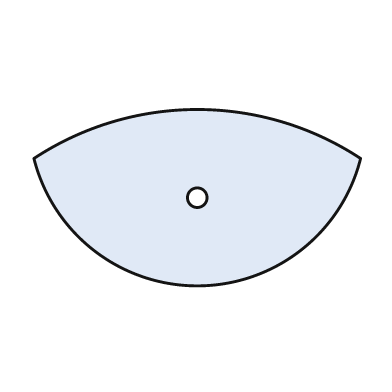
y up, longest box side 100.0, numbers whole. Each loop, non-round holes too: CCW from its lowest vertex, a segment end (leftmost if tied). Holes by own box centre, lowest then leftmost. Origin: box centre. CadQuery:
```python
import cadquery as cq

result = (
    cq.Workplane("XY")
    .moveTo(-50.0, 12.0)
    .threePointArc((0.0, -27.0), (50.0, 12.0))
    .threePointArc((0.0, 27.0), (-50.0, 12.0))
    .close()
    .moveTo(0.0, 0.0)
    .circle(3.0)
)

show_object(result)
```